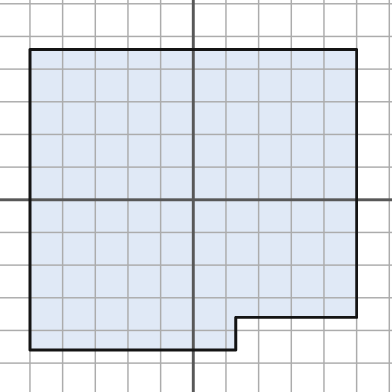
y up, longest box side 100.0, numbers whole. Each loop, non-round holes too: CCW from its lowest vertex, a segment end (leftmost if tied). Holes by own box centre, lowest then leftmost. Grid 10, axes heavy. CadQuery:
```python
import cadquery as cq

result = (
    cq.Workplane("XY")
    .moveTo(-50.0, -46.0)
    .lineTo(13.0, -46.0)
    .lineTo(13.0, -36.0)
    .lineTo(50.0, -36.0)
    .lineTo(50.0, 46.0)
    .lineTo(-50.0, 46.0)
    .close()
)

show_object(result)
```